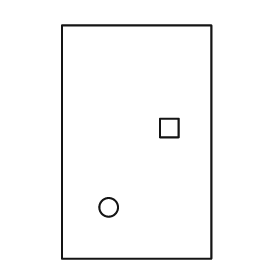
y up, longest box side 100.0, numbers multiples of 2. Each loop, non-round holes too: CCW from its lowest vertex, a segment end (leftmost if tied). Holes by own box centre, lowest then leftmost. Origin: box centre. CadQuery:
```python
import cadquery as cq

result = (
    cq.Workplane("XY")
    .moveTo(-32.0, -50.0)
    .lineTo(32.0, -50.0)
    .lineTo(32.0, 50.0)
    .lineTo(-32.0, 50.0)
    .close()
    .moveTo(-12.0, -28.0)
    .circle(4.0)
    .moveTo(10.0, 2.0)
    .lineTo(18.0, 2.0)
    .lineTo(18.0, 10.0)
    .lineTo(10.0, 10.0)
    .close()
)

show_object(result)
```